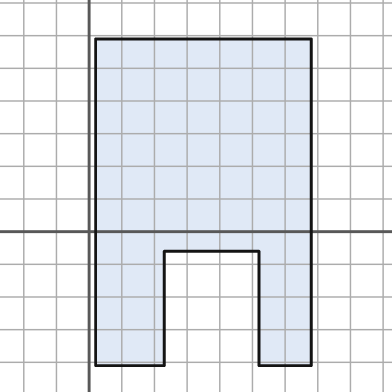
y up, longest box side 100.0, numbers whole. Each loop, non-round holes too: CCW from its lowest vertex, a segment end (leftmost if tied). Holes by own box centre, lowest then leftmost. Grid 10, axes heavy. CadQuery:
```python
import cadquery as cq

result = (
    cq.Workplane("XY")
    .moveTo(2.0, -41.0)
    .lineTo(23.0, -41.0)
    .lineTo(23.0, -6.0)
    .lineTo(52.0, -6.0)
    .lineTo(52.0, -41.0)
    .lineTo(68.0, -41.0)
    .lineTo(68.0, 59.0)
    .lineTo(2.0, 59.0)
    .close()
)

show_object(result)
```